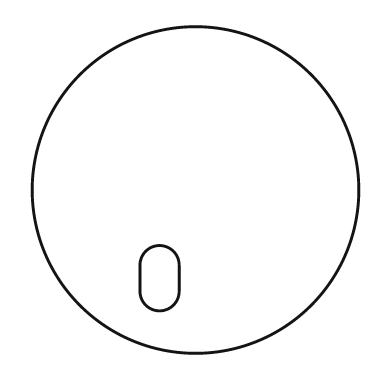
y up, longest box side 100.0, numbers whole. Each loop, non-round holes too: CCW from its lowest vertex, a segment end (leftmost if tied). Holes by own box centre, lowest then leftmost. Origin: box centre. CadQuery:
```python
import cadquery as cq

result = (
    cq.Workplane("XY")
    .moveTo(0.0, 0.0)
    .circle(50.0)
    .moveTo(-17.0, -31.0)
    .threePointArc((-11.0, -37.0), (-5.0, -31.0))
    .lineTo(-5.0, -23.0)
    .threePointArc((-11.0, -17.0), (-17.0, -23.0))
    .close()
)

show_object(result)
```